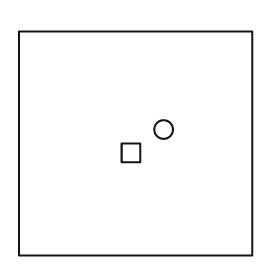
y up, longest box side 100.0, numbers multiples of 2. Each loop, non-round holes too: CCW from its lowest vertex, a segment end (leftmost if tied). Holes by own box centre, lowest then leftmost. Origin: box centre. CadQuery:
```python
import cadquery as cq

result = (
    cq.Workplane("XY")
    .moveTo(-50.0, -48.0)
    .lineTo(50.0, -48.0)
    .lineTo(50.0, 48.0)
    .lineTo(-50.0, 48.0)
    .close()
    .moveTo(-6.0, -8.0)
    .lineTo(2.0, -8.0)
    .lineTo(2.0, 0.0)
    .lineTo(-6.0, 0.0)
    .close()
    .moveTo(12.0, 6.0)
    .circle(4.0)
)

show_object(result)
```